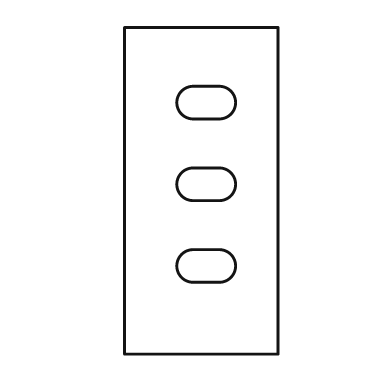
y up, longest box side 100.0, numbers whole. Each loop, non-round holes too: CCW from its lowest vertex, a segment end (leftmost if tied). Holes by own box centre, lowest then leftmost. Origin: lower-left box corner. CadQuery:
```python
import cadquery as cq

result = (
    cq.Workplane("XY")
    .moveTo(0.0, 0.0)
    .lineTo(47.0, 0.0)
    .lineTo(47.0, 100.0)
    .lineTo(0.0, 100.0)
    .close()
    .moveTo(21.0, 22.0)
    .lineTo(29.0, 22.0)
    .threePointArc((34.0, 27.0), (29.0, 32.0))
    .lineTo(21.0, 32.0)
    .threePointArc((16.0, 27.0), (21.0, 22.0))
    .close()
    .moveTo(21.0, 47.0)
    .lineTo(29.0, 47.0)
    .threePointArc((34.0, 52.0), (29.0, 57.0))
    .lineTo(21.0, 57.0)
    .threePointArc((16.0, 52.0), (21.0, 47.0))
    .close()
    .moveTo(21.0, 72.0)
    .lineTo(29.0, 72.0)
    .threePointArc((34.0, 77.0), (29.0, 82.0))
    .lineTo(21.0, 82.0)
    .threePointArc((16.0, 77.0), (21.0, 72.0))
    .close()
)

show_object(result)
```